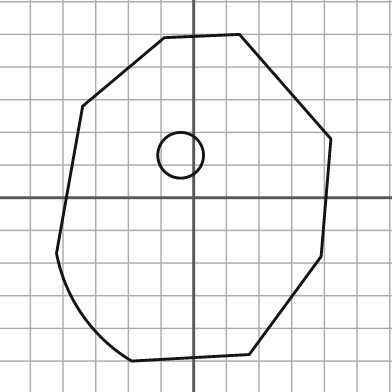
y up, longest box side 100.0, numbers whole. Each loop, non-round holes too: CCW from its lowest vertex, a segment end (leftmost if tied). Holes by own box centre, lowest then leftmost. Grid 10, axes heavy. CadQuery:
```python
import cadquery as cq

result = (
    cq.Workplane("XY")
    .moveTo(-19.0, -50.0)
    .lineTo(17.0, -48.0)
    .lineTo(39.0, -18.0)
    .lineTo(42.0, 18.0)
    .lineTo(14.0, 50.0)
    .lineTo(-9.0, 49.0)
    .lineTo(-34.0, 28.0)
    .lineTo(-42.0, -17.0)
    .threePointArc((-34.0, -36.0), (-19.0, -50.0))
    .close()
    .moveTo(-4.0, 13.0)
    .circle(7.0)
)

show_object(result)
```